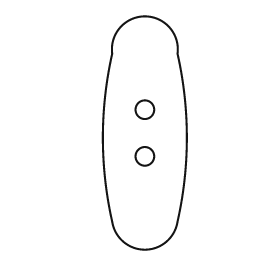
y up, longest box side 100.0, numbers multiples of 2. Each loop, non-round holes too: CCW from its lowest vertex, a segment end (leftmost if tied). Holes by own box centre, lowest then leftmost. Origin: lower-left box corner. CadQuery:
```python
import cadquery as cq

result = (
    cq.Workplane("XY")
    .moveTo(4.0, 12.0)
    .threePointArc((18.0, 0.0), (32.0, 12.0))
    .threePointArc((36.0, 48.0), (32.0, 84.0))
    .threePointArc((18.0, 100.0), (4.0, 84.0))
    .threePointArc((0.0, 48.0), (4.0, 12.0))
    .close()
    .moveTo(18.0, 40.0)
    .circle(4.0)
    .moveTo(18.0, 60.0)
    .circle(4.0)
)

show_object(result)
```